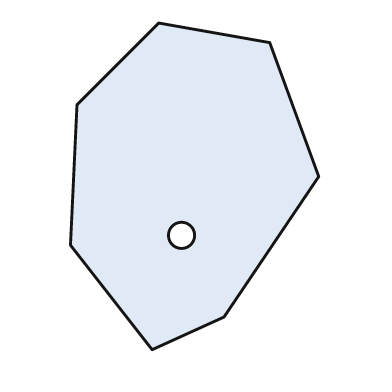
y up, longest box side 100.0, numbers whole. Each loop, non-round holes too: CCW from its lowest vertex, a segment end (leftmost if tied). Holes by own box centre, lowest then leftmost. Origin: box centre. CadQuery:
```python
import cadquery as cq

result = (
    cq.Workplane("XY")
    .moveTo(-13.0, -50.0)
    .lineTo(9.0, -40.0)
    .lineTo(38.0, 3.0)
    .lineTo(23.0, 44.0)
    .lineTo(-11.0, 50.0)
    .lineTo(-36.0, 25.0)
    .lineTo(-38.0, -18.0)
    .close()
    .moveTo(-4.0, -15.0)
    .circle(4.0)
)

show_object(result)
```